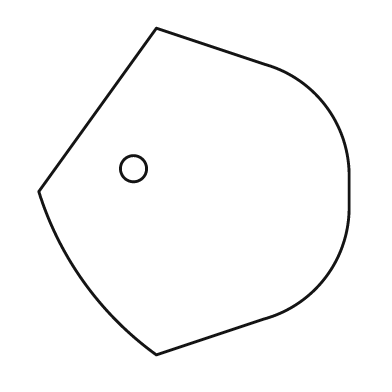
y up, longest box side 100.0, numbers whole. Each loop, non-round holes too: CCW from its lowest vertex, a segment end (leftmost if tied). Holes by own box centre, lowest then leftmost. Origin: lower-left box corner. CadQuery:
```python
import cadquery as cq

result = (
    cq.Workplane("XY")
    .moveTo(36.0, 0.0)
    .lineTo(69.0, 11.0)
    .threePointArc((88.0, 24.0), (95.0, 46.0))
    .lineTo(95.0, 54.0)
    .threePointArc((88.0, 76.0), (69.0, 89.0))
    .lineTo(36.0, 100.0)
    .lineTo(0.0, 50.0)
    .threePointArc((14.0, 22.0), (36.0, 0.0))
    .close()
    .moveTo(29.0, 57.0)
    .circle(4.0)
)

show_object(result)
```